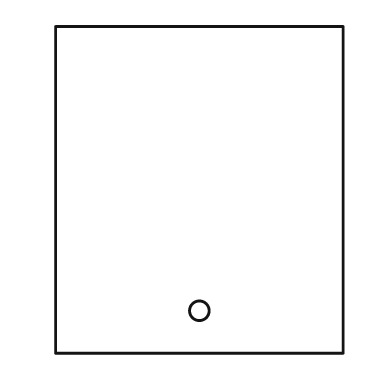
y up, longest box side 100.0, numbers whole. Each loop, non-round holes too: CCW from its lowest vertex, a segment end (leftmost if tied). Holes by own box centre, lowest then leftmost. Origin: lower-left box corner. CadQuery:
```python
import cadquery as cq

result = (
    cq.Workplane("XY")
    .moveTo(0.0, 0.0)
    .lineTo(88.0, 0.0)
    .lineTo(88.0, 100.0)
    .lineTo(0.0, 100.0)
    .close()
    .moveTo(44.0, 13.0)
    .circle(3.0)
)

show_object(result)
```